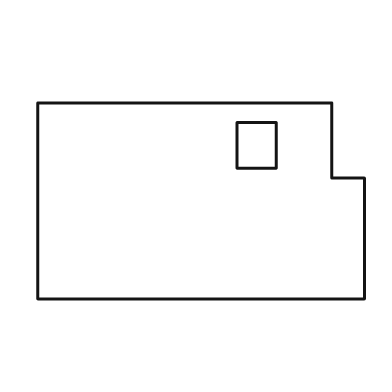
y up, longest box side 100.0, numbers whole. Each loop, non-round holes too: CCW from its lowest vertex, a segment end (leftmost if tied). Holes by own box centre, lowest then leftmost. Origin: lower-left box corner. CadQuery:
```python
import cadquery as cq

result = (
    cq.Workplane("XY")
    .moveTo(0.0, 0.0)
    .lineTo(100.0, 0.0)
    .lineTo(100.0, 37.0)
    .lineTo(90.0, 37.0)
    .lineTo(90.0, 60.0)
    .lineTo(0.0, 60.0)
    .close()
    .moveTo(61.0, 40.0)
    .lineTo(73.0, 40.0)
    .lineTo(73.0, 54.0)
    .lineTo(61.0, 54.0)
    .close()
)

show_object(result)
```